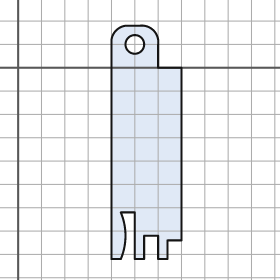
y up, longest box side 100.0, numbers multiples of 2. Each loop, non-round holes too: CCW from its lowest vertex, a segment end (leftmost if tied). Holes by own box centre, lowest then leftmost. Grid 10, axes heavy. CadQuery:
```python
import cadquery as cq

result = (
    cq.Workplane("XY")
    .moveTo(40.0, -82.0)
    .lineTo(44.0, -82.0)
    .threePointArc((46.0, -72.0), (44.0, -62.0))
    .lineTo(50.0, -62.0)
    .lineTo(50.0, -82.0)
    .lineTo(54.0, -82.0)
    .lineTo(54.0, -72.0)
    .lineTo(60.0, -72.0)
    .lineTo(60.0, -82.0)
    .lineTo(64.0, -82.0)
    .lineTo(64.0, -74.0)
    .lineTo(70.0, -74.0)
    .lineTo(70.0, 0.0)
    .lineTo(60.0, 0.0)
    .lineTo(60.0, 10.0)
    .threePointArc((58.0, 16.0), (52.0, 18.0))
    .lineTo(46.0, 18.0)
    .threePointArc((42.0, 16.0), (40.0, 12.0))
    .close()
    .moveTo(50.0, 10.0)
    .circle(4.0)
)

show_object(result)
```